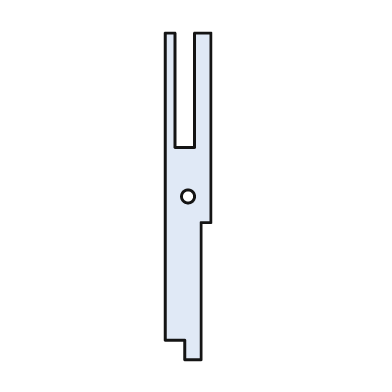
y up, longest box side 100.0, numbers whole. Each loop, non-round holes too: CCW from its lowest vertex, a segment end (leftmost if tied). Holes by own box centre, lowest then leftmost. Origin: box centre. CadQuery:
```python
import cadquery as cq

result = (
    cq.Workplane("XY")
    .moveTo(-1.0, -50.0)
    .lineTo(4.0, -50.0)
    .lineTo(4.0, -8.0)
    .lineTo(7.0, -8.0)
    .lineTo(7.0, 50.0)
    .lineTo(2.0, 50.0)
    .lineTo(2.0, 15.0)
    .lineTo(-4.0, 15.0)
    .lineTo(-4.0, 50.0)
    .lineTo(-7.0, 50.0)
    .lineTo(-7.0, -44.0)
    .lineTo(-1.0, -44.0)
    .close()
    .moveTo(0.0, 0.0)
    .circle(2.0)
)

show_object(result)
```